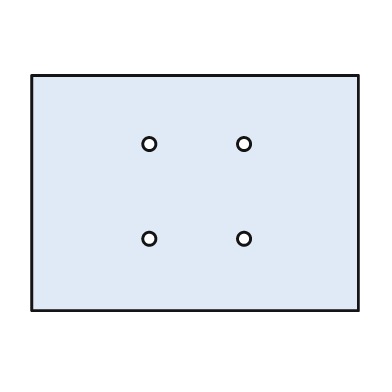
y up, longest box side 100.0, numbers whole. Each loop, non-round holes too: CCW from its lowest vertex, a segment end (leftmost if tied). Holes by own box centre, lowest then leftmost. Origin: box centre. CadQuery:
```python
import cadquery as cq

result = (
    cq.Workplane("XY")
    .moveTo(-50.0, -36.0)
    .lineTo(50.0, -36.0)
    .lineTo(50.0, 36.0)
    .lineTo(-50.0, 36.0)
    .close()
    .moveTo(-14.0, -14.0)
    .circle(2.0)
    .moveTo(15.0, -14.0)
    .circle(2.0)
    .moveTo(-14.0, 15.0)
    .circle(2.0)
    .moveTo(15.0, 15.0)
    .circle(2.0)
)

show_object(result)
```